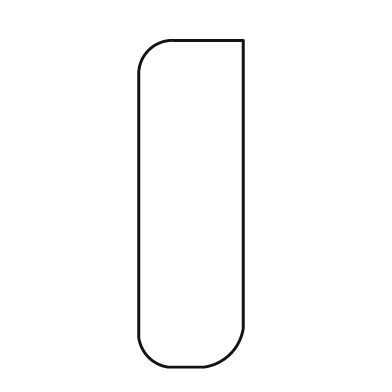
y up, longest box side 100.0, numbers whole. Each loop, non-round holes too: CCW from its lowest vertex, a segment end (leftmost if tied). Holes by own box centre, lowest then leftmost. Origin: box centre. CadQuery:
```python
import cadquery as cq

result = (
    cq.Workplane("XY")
    .moveTo(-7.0, -50.0)
    .lineTo(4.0, -50.0)
    .threePointArc((12.0, -46.0), (16.0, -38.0))
    .lineTo(16.0, 50.0)
    .lineTo(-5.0, 50.0)
    .threePointArc((-13.0, 47.0), (-16.0, 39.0))
    .lineTo(-16.0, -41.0)
    .threePointArc((-13.0, -47.0), (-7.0, -50.0))
    .close()
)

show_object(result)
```